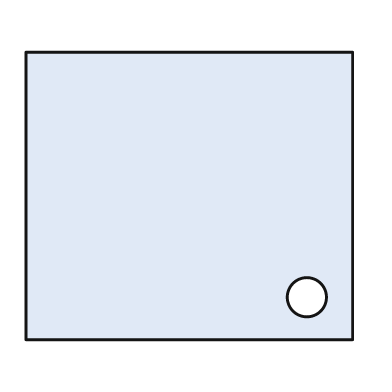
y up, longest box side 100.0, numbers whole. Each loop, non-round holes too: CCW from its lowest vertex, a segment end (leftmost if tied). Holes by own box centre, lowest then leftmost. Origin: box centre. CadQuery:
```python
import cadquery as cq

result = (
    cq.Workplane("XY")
    .moveTo(-50.0, -44.0)
    .lineTo(50.0, -44.0)
    .lineTo(50.0, 44.0)
    .lineTo(-50.0, 44.0)
    .close()
    .moveTo(36.0, -31.0)
    .circle(6.0)
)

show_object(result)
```